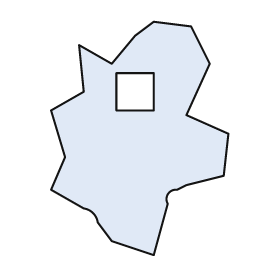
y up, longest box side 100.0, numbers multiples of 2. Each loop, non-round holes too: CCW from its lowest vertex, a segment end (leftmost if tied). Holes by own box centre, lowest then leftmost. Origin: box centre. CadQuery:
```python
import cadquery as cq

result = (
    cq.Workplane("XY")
    .moveTo(6.0, -50.0)
    .lineTo(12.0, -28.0)
    .threePointArc((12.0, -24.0), (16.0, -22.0))
    .lineTo(20.0, -20.0)
    .lineTo(36.0, -16.0)
    .lineTo(38.0, 2.0)
    .lineTo(20.0, 10.0)
    .lineTo(30.0, 32.0)
    .lineTo(22.0, 48.0)
    .lineTo(6.0, 50.0)
    .lineTo(-2.0, 44.0)
    .lineTo(-12.0, 32.0)
    .lineTo(-26.0, 40.0)
    .lineTo(-24.0, 20.0)
    .lineTo(-38.0, 12.0)
    .lineTo(-32.0, -8.0)
    .lineTo(-38.0, -22.0)
    .lineTo(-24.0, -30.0)
    .threePointArc((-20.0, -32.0), (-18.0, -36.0))
    .lineTo(-12.0, -44.0)
    .close()
    .moveTo(-10.0, 12.0)
    .lineTo(6.0, 12.0)
    .lineTo(6.0, 28.0)
    .lineTo(-10.0, 28.0)
    .close()
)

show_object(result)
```